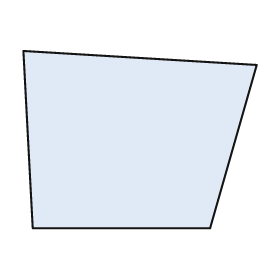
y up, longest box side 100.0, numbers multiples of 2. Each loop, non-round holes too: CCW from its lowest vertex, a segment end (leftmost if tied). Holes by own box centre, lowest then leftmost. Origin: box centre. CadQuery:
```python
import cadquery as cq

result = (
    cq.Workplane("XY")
    .moveTo(-46.0, -38.0)
    .lineTo(30.0, -38.0)
    .lineTo(50.0, 32.0)
    .lineTo(-50.0, 38.0)
    .close()
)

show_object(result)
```